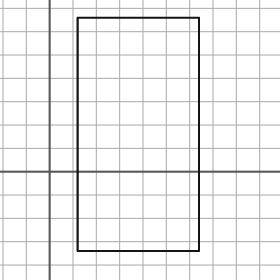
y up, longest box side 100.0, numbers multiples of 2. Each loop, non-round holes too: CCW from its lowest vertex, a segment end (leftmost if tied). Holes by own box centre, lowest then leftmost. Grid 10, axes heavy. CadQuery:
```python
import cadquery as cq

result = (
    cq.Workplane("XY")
    .moveTo(12.0, -34.0)
    .lineTo(64.0, -34.0)
    .lineTo(64.0, 66.0)
    .lineTo(12.0, 66.0)
    .close()
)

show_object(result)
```